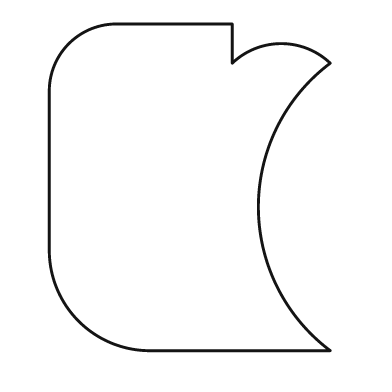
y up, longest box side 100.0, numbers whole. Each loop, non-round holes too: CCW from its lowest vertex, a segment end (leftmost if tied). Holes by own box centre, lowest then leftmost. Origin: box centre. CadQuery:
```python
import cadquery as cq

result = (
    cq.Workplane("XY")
    .moveTo(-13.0, -50.0)
    .lineTo(43.0, -50.0)
    .threePointArc((21.0, -6.0), (43.0, 38.0))
    .threePointArc((28.0, 44.0), (13.0, 38.0))
    .lineTo(13.0, 50.0)
    .lineTo(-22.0, 50.0)
    .threePointArc((-37.0, 44.0), (-43.0, 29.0))
    .lineTo(-43.0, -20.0)
    .threePointArc((-34.0, -41.0), (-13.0, -50.0))
    .close()
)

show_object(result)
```